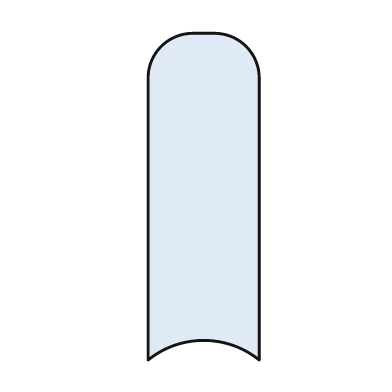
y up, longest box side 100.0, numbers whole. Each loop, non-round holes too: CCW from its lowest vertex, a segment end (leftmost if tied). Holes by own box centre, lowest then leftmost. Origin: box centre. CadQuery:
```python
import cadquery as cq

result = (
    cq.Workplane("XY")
    .moveTo(-17.0, -50.0)
    .threePointArc((0.0, -44.0), (17.0, -50.0))
    .lineTo(17.0, 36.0)
    .threePointArc((13.0, 46.0), (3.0, 50.0))
    .lineTo(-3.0, 50.0)
    .threePointArc((-13.0, 46.0), (-17.0, 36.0))
    .close()
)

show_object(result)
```